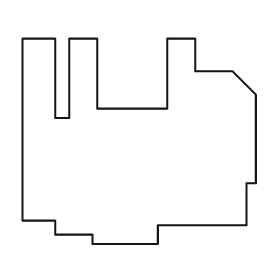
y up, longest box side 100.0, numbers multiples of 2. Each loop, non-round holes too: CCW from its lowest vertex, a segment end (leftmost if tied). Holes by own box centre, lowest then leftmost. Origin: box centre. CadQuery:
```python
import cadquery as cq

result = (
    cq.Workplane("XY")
    .moveTo(-20.0, -44.0)
    .lineTo(8.0, -44.0)
    .lineTo(8.0, -36.0)
    .lineTo(46.0, -36.0)
    .lineTo(46.0, -18.0)
    .lineTo(50.0, -18.0)
    .lineTo(50.0, 20.0)
    .lineTo(40.0, 30.0)
    .lineTo(24.0, 30.0)
    .lineTo(24.0, 44.0)
    .lineTo(12.0, 44.0)
    .lineTo(12.0, 14.0)
    .lineTo(-18.0, 14.0)
    .lineTo(-18.0, 44.0)
    .lineTo(-30.0, 44.0)
    .lineTo(-30.0, 10.0)
    .lineTo(-36.0, 10.0)
    .lineTo(-36.0, 44.0)
    .lineTo(-50.0, 44.0)
    .lineTo(-50.0, -34.0)
    .lineTo(-36.0, -34.0)
    .lineTo(-36.0, -40.0)
    .lineTo(-20.0, -40.0)
    .close()
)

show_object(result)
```